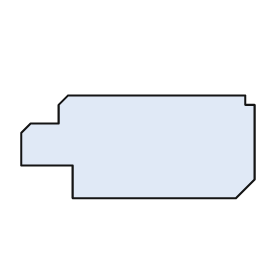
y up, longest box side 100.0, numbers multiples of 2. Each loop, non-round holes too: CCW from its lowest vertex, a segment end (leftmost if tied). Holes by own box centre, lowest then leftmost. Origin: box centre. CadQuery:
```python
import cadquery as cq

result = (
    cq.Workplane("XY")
    .moveTo(-28.0, -22.0)
    .lineTo(42.0, -22.0)
    .lineTo(50.0, -14.0)
    .lineTo(50.0, 18.0)
    .lineTo(46.0, 18.0)
    .lineTo(46.0, 22.0)
    .lineTo(-30.0, 22.0)
    .lineTo(-34.0, 18.0)
    .lineTo(-34.0, 10.0)
    .lineTo(-46.0, 10.0)
    .lineTo(-50.0, 6.0)
    .lineTo(-50.0, -8.0)
    .lineTo(-28.0, -8.0)
    .close()
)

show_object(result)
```